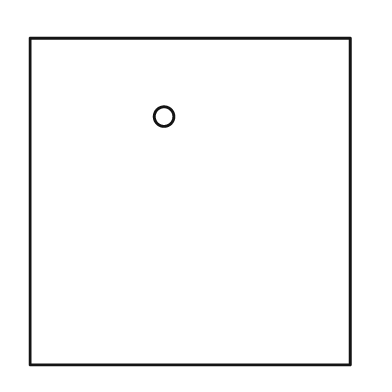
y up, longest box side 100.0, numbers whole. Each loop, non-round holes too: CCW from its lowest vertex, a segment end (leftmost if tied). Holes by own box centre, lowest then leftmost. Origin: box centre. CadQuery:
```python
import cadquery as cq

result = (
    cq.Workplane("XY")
    .moveTo(-49.0, -50.0)
    .lineTo(49.0, -50.0)
    .lineTo(49.0, 50.0)
    .lineTo(-49.0, 50.0)
    .close()
    .moveTo(-8.0, 26.0)
    .circle(3.0)
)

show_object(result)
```